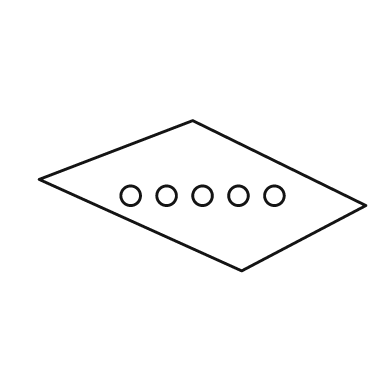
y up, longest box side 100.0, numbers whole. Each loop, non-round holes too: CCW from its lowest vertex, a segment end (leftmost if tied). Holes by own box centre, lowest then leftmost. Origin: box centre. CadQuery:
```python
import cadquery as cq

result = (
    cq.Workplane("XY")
    .moveTo(12.0, -23.0)
    .lineTo(50.0, -3.0)
    .lineTo(-3.0, 23.0)
    .lineTo(-50.0, 5.0)
    .close()
    .moveTo(-22.0, 0.0)
    .circle(3.0)
    .moveTo(-11.0, 0.0)
    .circle(3.0)
    .moveTo(0.0, 0.0)
    .circle(3.0)
    .moveTo(11.0, 0.0)
    .circle(3.0)
    .moveTo(22.0, 0.0)
    .circle(3.0)
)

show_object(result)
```